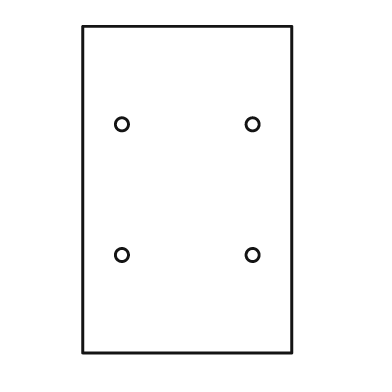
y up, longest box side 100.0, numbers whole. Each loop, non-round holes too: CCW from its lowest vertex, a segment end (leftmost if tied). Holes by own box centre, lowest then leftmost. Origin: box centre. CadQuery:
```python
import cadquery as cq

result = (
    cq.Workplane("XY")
    .moveTo(-32.0, -50.0)
    .lineTo(32.0, -50.0)
    .lineTo(32.0, 50.0)
    .lineTo(-32.0, 50.0)
    .close()
    .moveTo(-20.0, -20.0)
    .circle(2.0)
    .moveTo(20.0, -20.0)
    .circle(2.0)
    .moveTo(-20.0, 20.0)
    .circle(2.0)
    .moveTo(20.0, 20.0)
    .circle(2.0)
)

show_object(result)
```